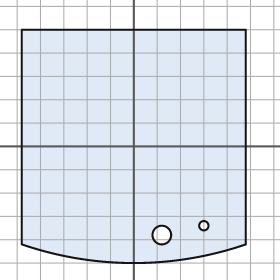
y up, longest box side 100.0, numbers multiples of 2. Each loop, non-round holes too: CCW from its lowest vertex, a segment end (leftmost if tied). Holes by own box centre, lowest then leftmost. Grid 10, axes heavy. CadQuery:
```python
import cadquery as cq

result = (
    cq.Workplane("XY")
    .moveTo(-48.0, -42.0)
    .threePointArc((0.0, -50.0), (48.0, -42.0))
    .lineTo(48.0, 50.0)
    .lineTo(-48.0, 50.0)
    .close()
    .moveTo(12.0, -38.0)
    .circle(4.0)
    .moveTo(30.0, -34.0)
    .circle(2.0)
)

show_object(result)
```